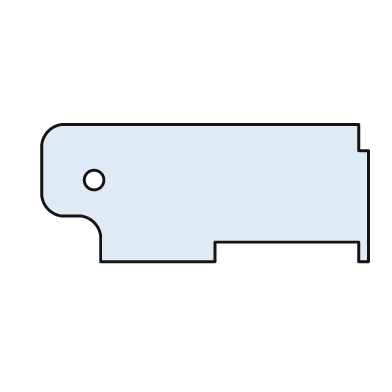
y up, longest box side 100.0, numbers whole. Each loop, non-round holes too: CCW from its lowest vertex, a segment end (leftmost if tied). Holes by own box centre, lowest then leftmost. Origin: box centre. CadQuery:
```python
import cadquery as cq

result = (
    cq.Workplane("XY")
    .moveTo(-32.0, -21.0)
    .lineTo(3.0, -21.0)
    .lineTo(3.0, -15.0)
    .lineTo(47.0, -15.0)
    .lineTo(47.0, -21.0)
    .lineTo(50.0, -21.0)
    .lineTo(50.0, 13.0)
    .lineTo(47.0, 13.0)
    .lineTo(47.0, 21.0)
    .lineTo(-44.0, 21.0)
    .threePointArc((-48.0, 19.0), (-50.0, 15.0))
    .lineTo(-50.0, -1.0)
    .threePointArc((-48.0, -5.0), (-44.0, -7.0))
    .lineTo(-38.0, -7.0)
    .threePointArc((-34.0, -9.0), (-32.0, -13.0))
    .close()
    .moveTo(-34.0, 4.0)
    .circle(3.0)
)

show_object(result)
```